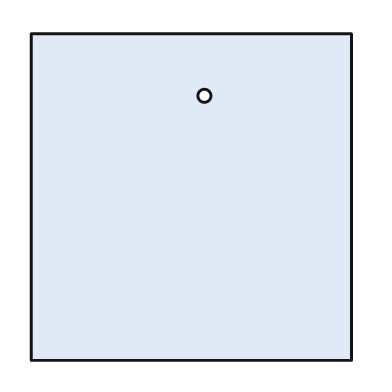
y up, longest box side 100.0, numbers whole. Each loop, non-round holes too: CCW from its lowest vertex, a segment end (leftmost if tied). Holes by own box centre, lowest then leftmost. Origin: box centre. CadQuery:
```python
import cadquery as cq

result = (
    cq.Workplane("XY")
    .moveTo(-49.0, -50.0)
    .lineTo(49.0, -50.0)
    .lineTo(49.0, 50.0)
    .lineTo(-49.0, 50.0)
    .close()
    .moveTo(4.0, 31.0)
    .circle(2.0)
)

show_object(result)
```